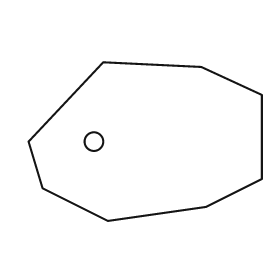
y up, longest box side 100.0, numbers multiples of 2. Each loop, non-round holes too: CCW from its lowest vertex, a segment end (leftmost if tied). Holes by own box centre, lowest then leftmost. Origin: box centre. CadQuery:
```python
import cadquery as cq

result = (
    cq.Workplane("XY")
    .moveTo(-16.0, -34.0)
    .lineTo(26.0, -28.0)
    .lineTo(50.0, -16.0)
    .lineTo(50.0, 20.0)
    .lineTo(24.0, 32.0)
    .lineTo(-18.0, 34.0)
    .lineTo(-50.0, 0.0)
    .lineTo(-44.0, -20.0)
    .close()
    .moveTo(-22.0, 0.0)
    .circle(4.0)
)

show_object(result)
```